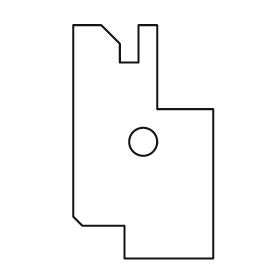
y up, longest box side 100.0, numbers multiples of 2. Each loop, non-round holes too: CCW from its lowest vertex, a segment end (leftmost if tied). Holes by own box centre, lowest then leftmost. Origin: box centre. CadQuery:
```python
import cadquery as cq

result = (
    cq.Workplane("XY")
    .moveTo(-8.0, -50.0)
    .lineTo(30.0, -50.0)
    .lineTo(30.0, 14.0)
    .lineTo(6.0, 14.0)
    .lineTo(6.0, 50.0)
    .lineTo(-2.0, 50.0)
    .lineTo(-2.0, 34.0)
    .lineTo(-10.0, 34.0)
    .lineTo(-10.0, 42.0)
    .lineTo(-18.0, 50.0)
    .lineTo(-30.0, 50.0)
    .lineTo(-30.0, -32.0)
    .lineTo(-26.0, -36.0)
    .lineTo(-8.0, -36.0)
    .close()
    .moveTo(0.0, 0.0)
    .circle(6.0)
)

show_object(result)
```